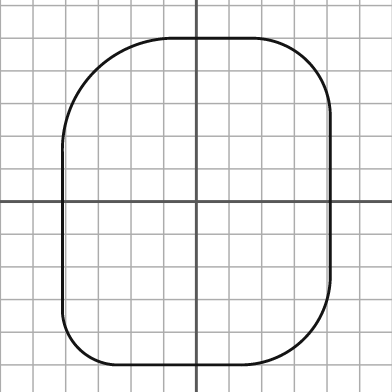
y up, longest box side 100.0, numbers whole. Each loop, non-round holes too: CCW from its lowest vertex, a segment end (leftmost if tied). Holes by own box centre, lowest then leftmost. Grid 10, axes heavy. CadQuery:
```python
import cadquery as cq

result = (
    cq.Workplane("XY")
    .moveTo(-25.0, -50.0)
    .lineTo(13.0, -50.0)
    .threePointArc((33.0, -42.0), (41.0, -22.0))
    .lineTo(41.0, 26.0)
    .threePointArc((34.0, 43.0), (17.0, 50.0))
    .lineTo(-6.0, 50.0)
    .threePointArc((-31.0, 40.0), (-41.0, 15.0))
    .lineTo(-41.0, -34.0)
    .threePointArc((-36.0, -45.0), (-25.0, -50.0))
    .close()
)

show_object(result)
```